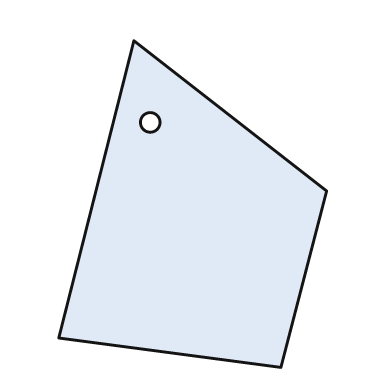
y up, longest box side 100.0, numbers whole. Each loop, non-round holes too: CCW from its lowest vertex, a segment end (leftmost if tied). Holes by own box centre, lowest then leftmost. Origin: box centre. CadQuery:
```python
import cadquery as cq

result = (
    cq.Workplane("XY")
    .moveTo(27.0, -50.0)
    .lineTo(41.0, 4.0)
    .lineTo(-18.0, 50.0)
    .lineTo(-41.0, -41.0)
    .close()
    .moveTo(-13.0, 25.0)
    .circle(3.0)
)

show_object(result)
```